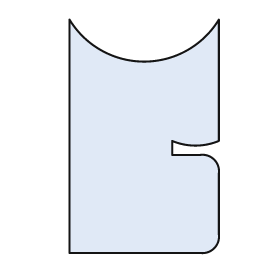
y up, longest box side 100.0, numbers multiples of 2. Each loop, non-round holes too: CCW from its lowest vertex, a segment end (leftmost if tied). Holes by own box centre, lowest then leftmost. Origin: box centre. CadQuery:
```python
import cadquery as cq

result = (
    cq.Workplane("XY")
    .moveTo(-32.0, -50.0)
    .lineTo(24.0, -50.0)
    .threePointArc((30.0, -48.0), (32.0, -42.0))
    .lineTo(32.0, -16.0)
    .threePointArc((30.0, -10.0), (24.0, -8.0))
    .lineTo(12.0, -8.0)
    .lineTo(12.0, -2.0)
    .threePointArc((22.0, -4.0), (32.0, -2.0))
    .lineTo(32.0, 50.0)
    .threePointArc((0.0, 32.0), (-32.0, 50.0))
    .close()
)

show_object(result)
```